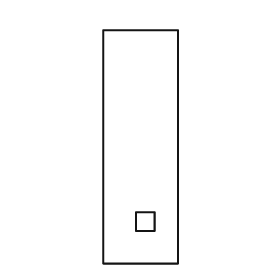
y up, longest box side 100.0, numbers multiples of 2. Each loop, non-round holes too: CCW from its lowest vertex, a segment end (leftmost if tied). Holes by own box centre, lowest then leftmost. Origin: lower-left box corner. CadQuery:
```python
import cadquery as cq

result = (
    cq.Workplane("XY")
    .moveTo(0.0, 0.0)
    .lineTo(32.0, 0.0)
    .lineTo(32.0, 100.0)
    .lineTo(0.0, 100.0)
    .close()
    .moveTo(14.0, 14.0)
    .lineTo(22.0, 14.0)
    .lineTo(22.0, 22.0)
    .lineTo(14.0, 22.0)
    .close()
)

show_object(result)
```